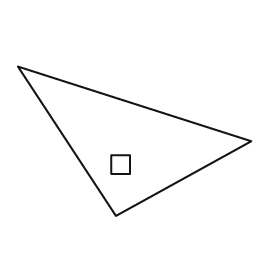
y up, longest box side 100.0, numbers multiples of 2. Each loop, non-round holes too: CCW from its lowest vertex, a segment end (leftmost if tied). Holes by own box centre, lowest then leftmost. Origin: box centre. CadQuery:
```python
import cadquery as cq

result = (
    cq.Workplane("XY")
    .moveTo(-8.0, -32.0)
    .lineTo(50.0, 0.0)
    .lineTo(-50.0, 32.0)
    .close()
    .moveTo(-10.0, -14.0)
    .lineTo(-2.0, -14.0)
    .lineTo(-2.0, -6.0)
    .lineTo(-10.0, -6.0)
    .close()
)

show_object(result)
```